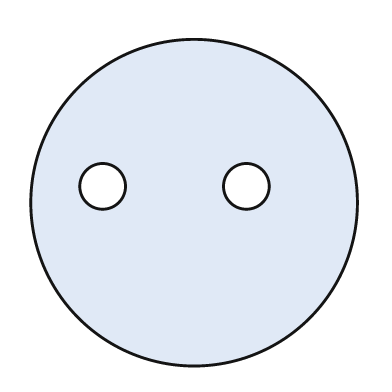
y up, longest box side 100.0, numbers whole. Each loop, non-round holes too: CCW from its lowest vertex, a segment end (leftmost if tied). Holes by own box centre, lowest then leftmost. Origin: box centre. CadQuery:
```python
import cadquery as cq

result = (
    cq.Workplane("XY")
    .moveTo(0.0, 0.0)
    .circle(50.0)
    .moveTo(-28.0, 5.0)
    .circle(7.0)
    .moveTo(16.0, 5.0)
    .circle(7.0)
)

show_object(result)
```